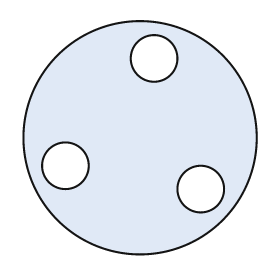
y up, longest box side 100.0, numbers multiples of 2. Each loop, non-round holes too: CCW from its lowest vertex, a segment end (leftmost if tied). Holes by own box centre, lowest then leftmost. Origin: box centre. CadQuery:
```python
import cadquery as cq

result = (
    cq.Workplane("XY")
    .moveTo(0.0, 0.0)
    .circle(50.0)
    .moveTo(26.0, -22.0)
    .circle(10.0)
    .moveTo(-32.0, -12.0)
    .circle(10.0)
    .moveTo(6.0, 34.0)
    .circle(10.0)
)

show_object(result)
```